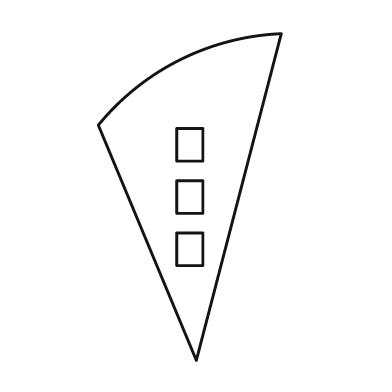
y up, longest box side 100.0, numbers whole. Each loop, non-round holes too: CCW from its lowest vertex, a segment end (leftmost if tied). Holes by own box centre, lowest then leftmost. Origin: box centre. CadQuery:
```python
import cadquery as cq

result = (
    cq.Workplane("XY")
    .moveTo(2.0, -50.0)
    .lineTo(28.0, 50.0)
    .threePointArc((-3.0, 42.0), (-28.0, 22.0))
    .close()
    .moveTo(-4.0, -21.0)
    .lineTo(4.0, -21.0)
    .lineTo(4.0, -11.0)
    .lineTo(-4.0, -11.0)
    .close()
    .moveTo(-4.0, -5.0)
    .lineTo(4.0, -5.0)
    .lineTo(4.0, 5.0)
    .lineTo(-4.0, 5.0)
    .close()
    .moveTo(-4.0, 11.0)
    .lineTo(4.0, 11.0)
    .lineTo(4.0, 21.0)
    .lineTo(-4.0, 21.0)
    .close()
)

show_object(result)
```